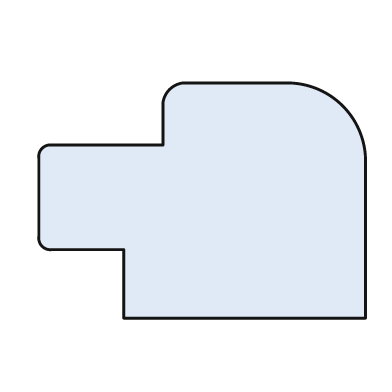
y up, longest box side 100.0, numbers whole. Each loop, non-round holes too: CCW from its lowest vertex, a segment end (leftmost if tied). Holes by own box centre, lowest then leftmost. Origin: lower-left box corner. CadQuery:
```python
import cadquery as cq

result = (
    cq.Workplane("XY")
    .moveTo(26.0, 0.0)
    .lineTo(100.0, 0.0)
    .lineTo(100.0, 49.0)
    .threePointArc((93.0, 65.0), (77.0, 72.0))
    .lineTo(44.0, 72.0)
    .threePointArc((40.0, 70.0), (38.0, 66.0))
    .lineTo(38.0, 53.0)
    .lineTo(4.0, 53.0)
    .threePointArc((1.0, 52.0), (0.0, 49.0))
    .lineTo(0.0, 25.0)
    .threePointArc((1.0, 22.0), (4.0, 21.0))
    .lineTo(26.0, 21.0)
    .close()
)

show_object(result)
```